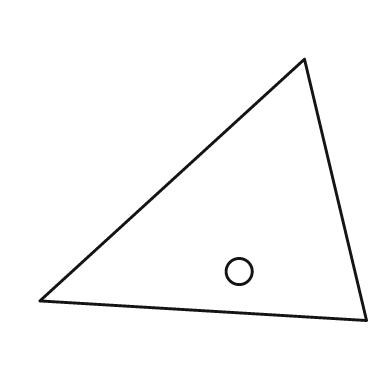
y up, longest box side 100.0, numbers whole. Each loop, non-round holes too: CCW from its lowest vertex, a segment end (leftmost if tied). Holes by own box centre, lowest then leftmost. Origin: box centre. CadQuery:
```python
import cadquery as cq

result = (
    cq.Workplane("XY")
    .moveTo(50.0, -40.0)
    .lineTo(31.0, 40.0)
    .lineTo(-50.0, -34.0)
    .close()
    .moveTo(11.0, -25.0)
    .circle(4.0)
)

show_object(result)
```